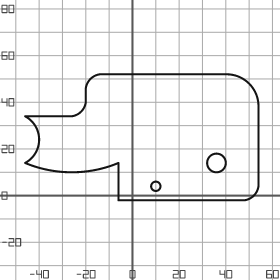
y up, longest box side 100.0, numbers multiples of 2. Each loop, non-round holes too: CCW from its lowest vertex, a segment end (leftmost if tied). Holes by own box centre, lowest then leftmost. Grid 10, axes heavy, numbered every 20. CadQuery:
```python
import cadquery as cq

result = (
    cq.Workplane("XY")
    .moveTo(-6.0, -2.0)
    .lineTo(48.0, -2.0)
    .threePointArc((52.0, 0.0), (54.0, 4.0))
    .lineTo(54.0, 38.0)
    .threePointArc((50.0, 48.0), (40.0, 52.0))
    .lineTo(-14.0, 52.0)
    .threePointArc((-18.0, 50.0), (-20.0, 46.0))
    .lineTo(-20.0, 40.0)
    .threePointArc((-22.0, 36.0), (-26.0, 34.0))
    .lineTo(-46.0, 34.0)
    .threePointArc((-40.0, 24.0), (-46.0, 14.0))
    .threePointArc((-26.0, 10.0), (-6.0, 14.0))
    .close()
    .moveTo(10.0, 4.0)
    .circle(2.0)
    .moveTo(36.0, 14.0)
    .circle(4.0)
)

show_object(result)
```